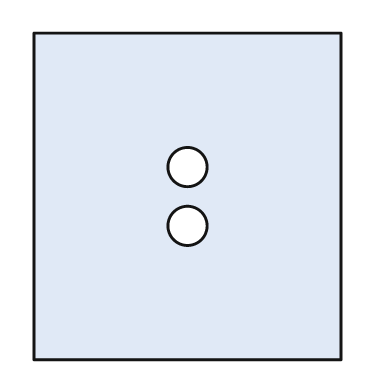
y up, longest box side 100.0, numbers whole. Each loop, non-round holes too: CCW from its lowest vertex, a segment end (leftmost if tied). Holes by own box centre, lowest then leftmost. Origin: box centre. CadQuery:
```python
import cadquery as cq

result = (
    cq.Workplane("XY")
    .moveTo(-47.0, -50.0)
    .lineTo(47.0, -50.0)
    .lineTo(47.0, 50.0)
    .lineTo(-47.0, 50.0)
    .close()
    .moveTo(0.0, -9.0)
    .circle(6.0)
    .moveTo(0.0, 9.0)
    .circle(6.0)
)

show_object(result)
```